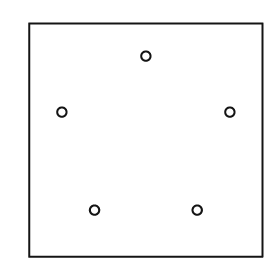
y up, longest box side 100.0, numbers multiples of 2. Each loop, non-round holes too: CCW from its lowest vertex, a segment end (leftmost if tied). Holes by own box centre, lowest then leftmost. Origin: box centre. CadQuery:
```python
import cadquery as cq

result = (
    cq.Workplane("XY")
    .moveTo(-50.0, -50.0)
    .lineTo(50.0, -50.0)
    .lineTo(50.0, 50.0)
    .lineTo(-50.0, 50.0)
    .close()
    .moveTo(-22.0, -30.0)
    .circle(2.0)
    .moveTo(22.0, -30.0)
    .circle(2.0)
    .moveTo(-36.0, 12.0)
    .circle(2.0)
    .moveTo(36.0, 12.0)
    .circle(2.0)
    .moveTo(0.0, 36.0)
    .circle(2.0)
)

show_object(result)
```